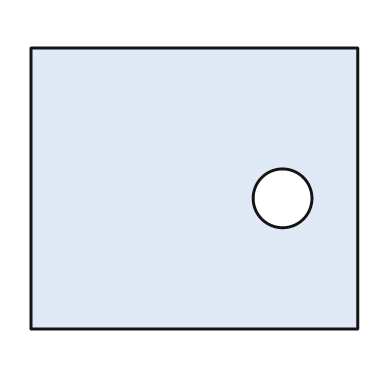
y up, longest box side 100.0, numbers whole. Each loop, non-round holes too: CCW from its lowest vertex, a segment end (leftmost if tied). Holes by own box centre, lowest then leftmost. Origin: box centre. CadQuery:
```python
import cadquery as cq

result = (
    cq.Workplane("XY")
    .moveTo(-50.0, -43.0)
    .lineTo(50.0, -43.0)
    .lineTo(50.0, 43.0)
    .lineTo(-50.0, 43.0)
    .close()
    .moveTo(27.0, -3.0)
    .circle(9.0)
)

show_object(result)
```